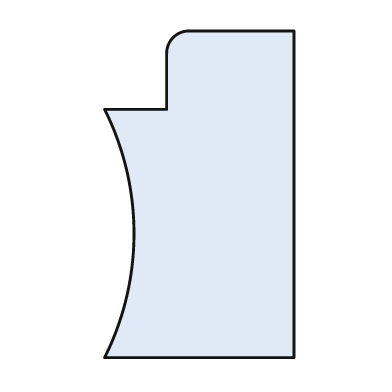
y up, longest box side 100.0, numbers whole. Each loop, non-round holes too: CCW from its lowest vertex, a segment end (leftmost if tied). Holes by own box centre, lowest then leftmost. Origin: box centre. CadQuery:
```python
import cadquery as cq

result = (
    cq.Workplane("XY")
    .moveTo(-29.0, -50.0)
    .lineTo(29.0, -50.0)
    .lineTo(29.0, 50.0)
    .lineTo(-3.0, 50.0)
    .threePointArc((-8.0, 48.0), (-10.0, 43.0))
    .lineTo(-10.0, 26.0)
    .lineTo(-29.0, 26.0)
    .threePointArc((-20.0, -12.0), (-29.0, -50.0))
    .close()
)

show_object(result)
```